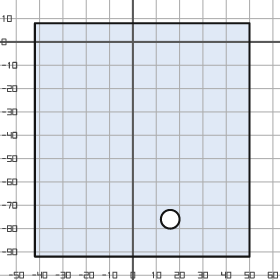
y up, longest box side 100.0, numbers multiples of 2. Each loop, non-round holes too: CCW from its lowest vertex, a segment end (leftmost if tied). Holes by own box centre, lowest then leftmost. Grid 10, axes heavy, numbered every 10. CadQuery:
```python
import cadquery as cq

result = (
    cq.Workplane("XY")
    .moveTo(-42.0, -92.0)
    .lineTo(50.0, -92.0)
    .lineTo(50.0, 8.0)
    .lineTo(-42.0, 8.0)
    .close()
    .moveTo(16.0, -76.0)
    .circle(4.0)
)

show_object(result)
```